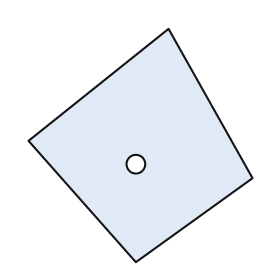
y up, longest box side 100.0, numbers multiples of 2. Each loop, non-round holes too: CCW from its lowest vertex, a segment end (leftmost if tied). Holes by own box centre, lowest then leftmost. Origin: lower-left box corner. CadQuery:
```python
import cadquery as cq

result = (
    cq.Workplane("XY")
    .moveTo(46.0, 0.0)
    .lineTo(96.0, 36.0)
    .lineTo(60.0, 100.0)
    .lineTo(0.0, 52.0)
    .close()
    .moveTo(46.0, 42.0)
    .circle(4.0)
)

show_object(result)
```